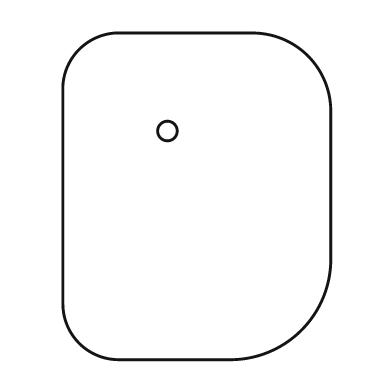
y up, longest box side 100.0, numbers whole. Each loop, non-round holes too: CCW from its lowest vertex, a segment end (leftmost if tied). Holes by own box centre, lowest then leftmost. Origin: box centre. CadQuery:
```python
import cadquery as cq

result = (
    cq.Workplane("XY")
    .moveTo(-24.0, -50.0)
    .lineTo(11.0, -50.0)
    .threePointArc((32.0, -41.0), (41.0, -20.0))
    .lineTo(41.0, 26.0)
    .threePointArc((34.0, 43.0), (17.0, 50.0))
    .lineTo(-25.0, 50.0)
    .threePointArc((-36.0, 45.0), (-41.0, 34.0))
    .lineTo(-41.0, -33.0)
    .threePointArc((-36.0, -45.0), (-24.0, -50.0))
    .close()
    .moveTo(-9.0, 20.0)
    .circle(3.0)
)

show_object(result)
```